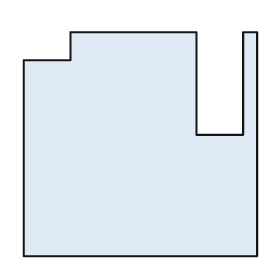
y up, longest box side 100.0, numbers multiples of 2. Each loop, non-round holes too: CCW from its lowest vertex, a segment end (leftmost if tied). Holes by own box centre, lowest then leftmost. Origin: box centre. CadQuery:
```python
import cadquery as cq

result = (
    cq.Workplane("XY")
    .moveTo(-50.0, -48.0)
    .lineTo(50.0, -48.0)
    .lineTo(50.0, 48.0)
    .lineTo(44.0, 48.0)
    .lineTo(44.0, 4.0)
    .lineTo(24.0, 4.0)
    .lineTo(24.0, 48.0)
    .lineTo(-30.0, 48.0)
    .lineTo(-30.0, 36.0)
    .lineTo(-50.0, 36.0)
    .close()
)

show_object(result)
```